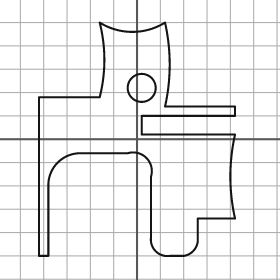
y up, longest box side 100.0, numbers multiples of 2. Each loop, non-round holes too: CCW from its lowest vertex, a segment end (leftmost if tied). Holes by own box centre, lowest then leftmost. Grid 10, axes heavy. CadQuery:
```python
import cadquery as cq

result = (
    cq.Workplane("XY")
    .moveTo(-42.0, -50.0)
    .lineTo(-38.0, -50.0)
    .lineTo(-38.0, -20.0)
    .threePointArc((-34.0, -10.0), (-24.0, -6.0))
    .lineTo(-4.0, -6.0)
    .threePointArc((4.0, -8.0), (6.0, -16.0))
    .lineTo(6.0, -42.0)
    .threePointArc((8.0, -48.0), (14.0, -50.0))
    .lineTo(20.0, -50.0)
    .threePointArc((24.0, -48.0), (26.0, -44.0))
    .lineTo(26.0, -34.0)
    .lineTo(42.0, -34.0)
    .threePointArc((40.0, -16.0), (42.0, 2.0))
    .lineTo(2.0, 2.0)
    .lineTo(2.0, 10.0)
    .lineTo(42.0, 10.0)
    .lineTo(42.0, 14.0)
    .lineTo(12.0, 14.0)
    .threePointArc((14.0, 32.0), (12.0, 50.0))
    .threePointArc((-2.0, 46.0), (-16.0, 50.0))
    .threePointArc((-14.0, 34.0), (-16.0, 18.0))
    .lineTo(-42.0, 18.0)
    .close()
    .moveTo(2.0, 22.0)
    .circle(6.0)
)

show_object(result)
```